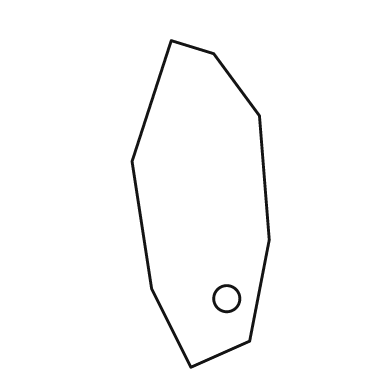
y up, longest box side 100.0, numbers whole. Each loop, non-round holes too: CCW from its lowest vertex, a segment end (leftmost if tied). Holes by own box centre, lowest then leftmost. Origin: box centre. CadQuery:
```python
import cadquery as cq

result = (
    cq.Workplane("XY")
    .moveTo(-3.0, -50.0)
    .lineTo(15.0, -42.0)
    .lineTo(21.0, -11.0)
    .lineTo(18.0, 27.0)
    .lineTo(4.0, 46.0)
    .lineTo(-9.0, 50.0)
    .lineTo(-21.0, 13.0)
    .lineTo(-15.0, -26.0)
    .close()
    .moveTo(8.0, -29.0)
    .circle(4.0)
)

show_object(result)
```